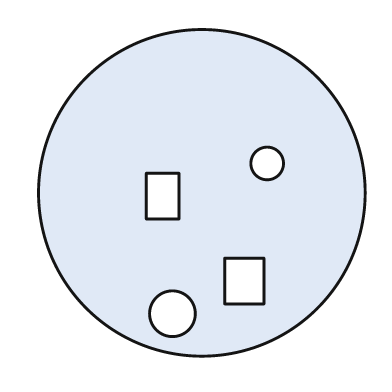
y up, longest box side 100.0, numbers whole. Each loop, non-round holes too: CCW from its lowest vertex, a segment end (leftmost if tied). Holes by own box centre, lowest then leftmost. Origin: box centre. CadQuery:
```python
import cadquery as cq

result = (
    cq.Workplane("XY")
    .moveTo(0.0, 0.0)
    .circle(50.0)
    .moveTo(-9.0, -37.0)
    .circle(7.0)
    .moveTo(7.0, -34.0)
    .lineTo(19.0, -34.0)
    .lineTo(19.0, -20.0)
    .lineTo(7.0, -20.0)
    .close()
    .moveTo(-17.0, -8.0)
    .lineTo(-7.0, -8.0)
    .lineTo(-7.0, 6.0)
    .lineTo(-17.0, 6.0)
    .close()
    .moveTo(20.0, 9.0)
    .circle(5.0)
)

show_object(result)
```